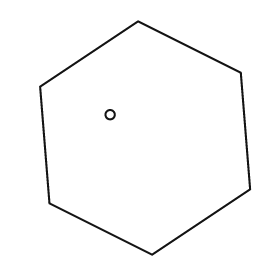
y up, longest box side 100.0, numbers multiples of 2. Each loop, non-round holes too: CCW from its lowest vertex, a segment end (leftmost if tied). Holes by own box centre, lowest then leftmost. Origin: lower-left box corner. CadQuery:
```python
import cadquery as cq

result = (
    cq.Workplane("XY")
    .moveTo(48.0, 0.0)
    .lineTo(90.0, 28.0)
    .lineTo(86.0, 78.0)
    .lineTo(42.0, 100.0)
    .lineTo(0.0, 72.0)
    .lineTo(4.0, 22.0)
    .close()
    .moveTo(30.0, 60.0)
    .circle(2.0)
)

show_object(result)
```